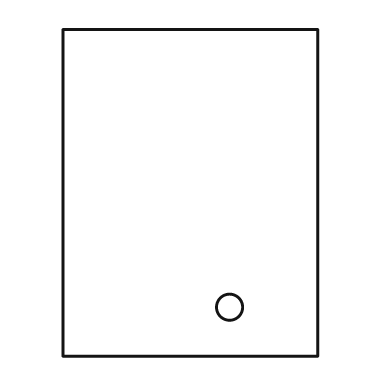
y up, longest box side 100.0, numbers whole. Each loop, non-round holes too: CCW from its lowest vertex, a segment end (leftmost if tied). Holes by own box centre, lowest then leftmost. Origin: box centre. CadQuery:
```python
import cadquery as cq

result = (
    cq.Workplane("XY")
    .moveTo(-39.0, -50.0)
    .lineTo(39.0, -50.0)
    .lineTo(39.0, 50.0)
    .lineTo(-39.0, 50.0)
    .close()
    .moveTo(12.0, -35.0)
    .circle(4.0)
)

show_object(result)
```